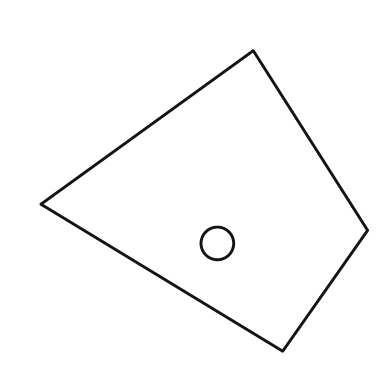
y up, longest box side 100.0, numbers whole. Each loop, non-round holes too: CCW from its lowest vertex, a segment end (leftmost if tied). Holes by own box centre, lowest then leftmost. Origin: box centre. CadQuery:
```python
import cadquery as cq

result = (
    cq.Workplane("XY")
    .moveTo(24.0, -46.0)
    .lineTo(50.0, -9.0)
    .lineTo(15.0, 46.0)
    .lineTo(-50.0, -1.0)
    .close()
    .moveTo(4.0, -13.0)
    .circle(5.0)
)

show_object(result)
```